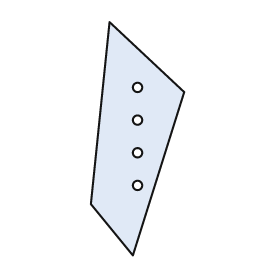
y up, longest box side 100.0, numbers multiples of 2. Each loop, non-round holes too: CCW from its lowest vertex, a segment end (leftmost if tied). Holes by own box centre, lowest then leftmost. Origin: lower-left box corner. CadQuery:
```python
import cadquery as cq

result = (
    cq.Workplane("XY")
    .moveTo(18.0, 0.0)
    .lineTo(40.0, 70.0)
    .lineTo(8.0, 100.0)
    .lineTo(0.0, 22.0)
    .close()
    .moveTo(20.0, 30.0)
    .circle(2.0)
    .moveTo(20.0, 44.0)
    .circle(2.0)
    .moveTo(20.0, 58.0)
    .circle(2.0)
    .moveTo(20.0, 72.0)
    .circle(2.0)
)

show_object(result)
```